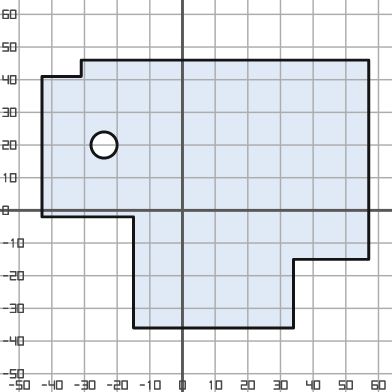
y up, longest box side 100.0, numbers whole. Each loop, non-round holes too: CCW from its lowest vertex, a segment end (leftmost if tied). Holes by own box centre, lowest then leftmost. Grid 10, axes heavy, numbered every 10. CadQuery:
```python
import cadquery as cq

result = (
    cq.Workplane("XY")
    .moveTo(-15.0, -36.0)
    .lineTo(34.0, -36.0)
    .lineTo(34.0, -15.0)
    .lineTo(57.0, -15.0)
    .lineTo(57.0, 46.0)
    .lineTo(-31.0, 46.0)
    .lineTo(-31.0, 41.0)
    .lineTo(-43.0, 41.0)
    .lineTo(-43.0, -2.0)
    .lineTo(-15.0, -2.0)
    .close()
    .moveTo(-24.0, 20.0)
    .circle(4.0)
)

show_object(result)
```